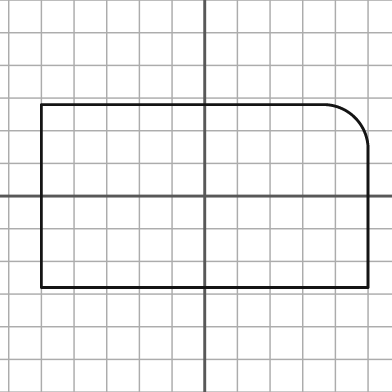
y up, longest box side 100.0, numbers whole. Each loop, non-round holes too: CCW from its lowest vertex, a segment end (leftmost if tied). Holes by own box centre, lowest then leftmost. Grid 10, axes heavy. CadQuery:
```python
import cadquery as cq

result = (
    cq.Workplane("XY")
    .moveTo(-50.0, -28.0)
    .lineTo(50.0, -28.0)
    .lineTo(50.0, 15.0)
    .threePointArc((46.0, 24.0), (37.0, 28.0))
    .lineTo(-50.0, 28.0)
    .close()
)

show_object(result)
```